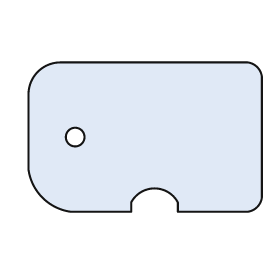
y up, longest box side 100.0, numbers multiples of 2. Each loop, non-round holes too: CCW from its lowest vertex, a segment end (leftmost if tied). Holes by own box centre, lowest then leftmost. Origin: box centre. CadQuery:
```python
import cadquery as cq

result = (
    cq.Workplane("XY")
    .moveTo(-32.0, -32.0)
    .lineTo(-6.0, -32.0)
    .lineTo(-6.0, -28.0)
    .threePointArc((4.0, -22.0), (14.0, -28.0))
    .lineTo(14.0, -32.0)
    .lineTo(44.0, -32.0)
    .threePointArc((48.0, -30.0), (50.0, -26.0))
    .lineTo(50.0, 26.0)
    .threePointArc((48.0, 30.0), (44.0, 32.0))
    .lineTo(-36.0, 32.0)
    .threePointArc((-46.0, 28.0), (-50.0, 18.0))
    .lineTo(-50.0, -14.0)
    .threePointArc((-44.0, -26.0), (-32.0, -32.0))
    .close()
    .moveTo(-30.0, 0.0)
    .circle(4.0)
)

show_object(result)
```